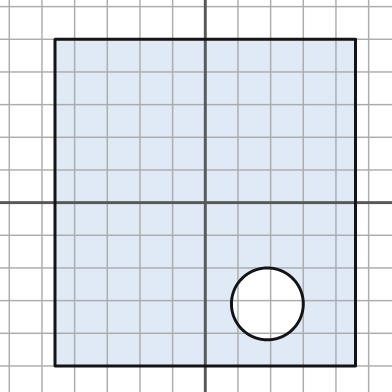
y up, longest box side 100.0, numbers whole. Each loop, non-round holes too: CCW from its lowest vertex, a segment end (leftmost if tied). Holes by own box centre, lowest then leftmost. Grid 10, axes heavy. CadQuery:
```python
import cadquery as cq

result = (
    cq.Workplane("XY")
    .moveTo(-46.0, -50.0)
    .lineTo(46.0, -50.0)
    .lineTo(46.0, 50.0)
    .lineTo(-46.0, 50.0)
    .close()
    .moveTo(19.0, -31.0)
    .circle(11.0)
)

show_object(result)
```